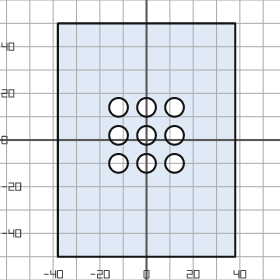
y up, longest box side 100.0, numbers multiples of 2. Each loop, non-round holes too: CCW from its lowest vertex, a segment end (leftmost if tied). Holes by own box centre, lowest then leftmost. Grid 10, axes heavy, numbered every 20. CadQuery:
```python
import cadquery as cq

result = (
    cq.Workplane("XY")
    .moveTo(-38.0, -50.0)
    .lineTo(38.0, -50.0)
    .lineTo(38.0, 50.0)
    .lineTo(-38.0, 50.0)
    .close()
    .moveTo(-12.0, -10.0)
    .circle(4.0)
    .moveTo(0.0, -10.0)
    .circle(4.0)
    .moveTo(12.0, -10.0)
    .circle(4.0)
    .moveTo(-12.0, 2.0)
    .circle(4.0)
    .moveTo(0.0, 2.0)
    .circle(4.0)
    .moveTo(12.0, 2.0)
    .circle(4.0)
    .moveTo(-12.0, 14.0)
    .circle(4.0)
    .moveTo(0.0, 14.0)
    .circle(4.0)
    .moveTo(12.0, 14.0)
    .circle(4.0)
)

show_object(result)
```